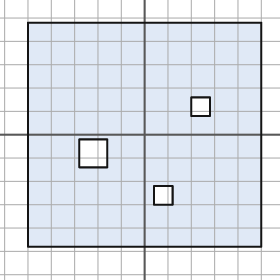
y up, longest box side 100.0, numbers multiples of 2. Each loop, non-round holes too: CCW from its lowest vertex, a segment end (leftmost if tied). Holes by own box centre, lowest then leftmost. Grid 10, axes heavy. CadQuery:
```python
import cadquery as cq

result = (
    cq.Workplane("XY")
    .moveTo(-50.0, -48.0)
    .lineTo(50.0, -48.0)
    .lineTo(50.0, 48.0)
    .lineTo(-50.0, 48.0)
    .close()
    .moveTo(4.0, -30.0)
    .lineTo(12.0, -30.0)
    .lineTo(12.0, -22.0)
    .lineTo(4.0, -22.0)
    .close()
    .moveTo(-28.0, -14.0)
    .lineTo(-16.0, -14.0)
    .lineTo(-16.0, -2.0)
    .lineTo(-28.0, -2.0)
    .close()
    .moveTo(20.0, 8.0)
    .lineTo(28.0, 8.0)
    .lineTo(28.0, 16.0)
    .lineTo(20.0, 16.0)
    .close()
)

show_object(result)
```